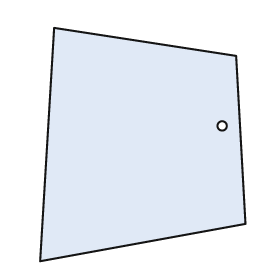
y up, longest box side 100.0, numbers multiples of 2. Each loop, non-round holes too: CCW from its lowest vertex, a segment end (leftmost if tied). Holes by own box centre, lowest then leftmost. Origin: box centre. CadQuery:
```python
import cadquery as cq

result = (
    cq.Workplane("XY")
    .moveTo(-44.0, -50.0)
    .lineTo(44.0, -34.0)
    .lineTo(40.0, 38.0)
    .lineTo(-38.0, 50.0)
    .close()
    .moveTo(34.0, 8.0)
    .circle(2.0)
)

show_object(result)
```